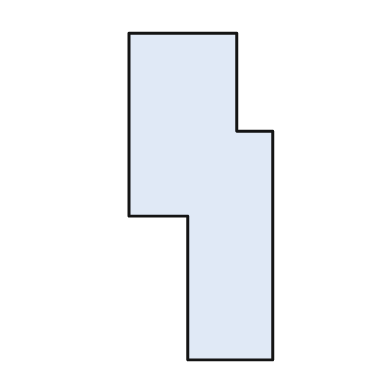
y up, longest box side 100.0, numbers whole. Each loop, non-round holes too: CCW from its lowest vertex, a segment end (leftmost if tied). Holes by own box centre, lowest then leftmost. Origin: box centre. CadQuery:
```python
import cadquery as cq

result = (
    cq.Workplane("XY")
    .moveTo(-4.0, -50.0)
    .lineTo(22.0, -50.0)
    .lineTo(22.0, 20.0)
    .lineTo(11.0, 20.0)
    .lineTo(11.0, 50.0)
    .lineTo(-22.0, 50.0)
    .lineTo(-22.0, -6.0)
    .lineTo(-4.0, -6.0)
    .close()
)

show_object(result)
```